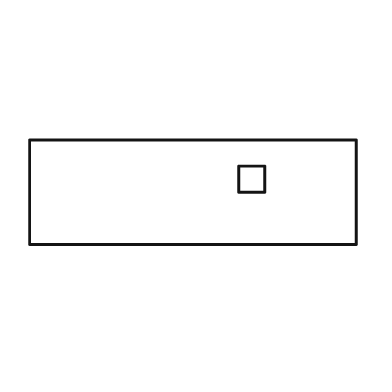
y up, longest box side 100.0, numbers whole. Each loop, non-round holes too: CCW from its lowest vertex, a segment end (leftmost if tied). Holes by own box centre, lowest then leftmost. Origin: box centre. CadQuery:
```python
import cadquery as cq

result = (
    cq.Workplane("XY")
    .moveTo(-50.0, -16.0)
    .lineTo(50.0, -16.0)
    .lineTo(50.0, 16.0)
    .lineTo(-50.0, 16.0)
    .close()
    .moveTo(14.0, 0.0)
    .lineTo(22.0, 0.0)
    .lineTo(22.0, 8.0)
    .lineTo(14.0, 8.0)
    .close()
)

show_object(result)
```